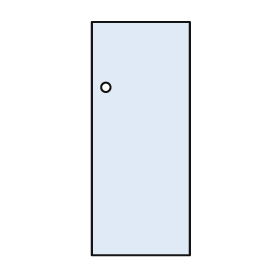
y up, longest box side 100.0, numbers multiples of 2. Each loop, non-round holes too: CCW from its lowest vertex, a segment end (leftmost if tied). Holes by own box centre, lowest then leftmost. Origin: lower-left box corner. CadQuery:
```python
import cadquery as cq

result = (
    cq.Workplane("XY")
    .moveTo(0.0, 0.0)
    .lineTo(42.0, 0.0)
    .lineTo(42.0, 100.0)
    .lineTo(0.0, 100.0)
    .close()
    .moveTo(6.0, 72.0)
    .circle(2.0)
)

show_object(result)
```